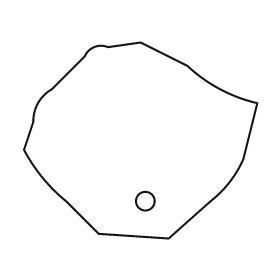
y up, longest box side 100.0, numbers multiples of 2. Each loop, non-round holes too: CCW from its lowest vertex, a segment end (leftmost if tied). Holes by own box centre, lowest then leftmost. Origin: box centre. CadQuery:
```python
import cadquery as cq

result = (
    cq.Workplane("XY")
    .moveTo(12.0, -42.0)
    .lineTo(30.0, -26.0)
    .threePointArc((38.0, -18.0), (44.0, -8.0))
    .lineTo(50.0, 16.0)
    .threePointArc((34.0, 22.0), (20.0, 32.0))
    .lineTo(0.0, 42.0)
    .lineTo(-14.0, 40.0)
    .threePointArc((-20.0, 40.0), (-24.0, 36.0))
    .lineTo(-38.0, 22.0)
    .threePointArc((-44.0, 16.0), (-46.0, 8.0))
    .lineTo(-50.0, -4.0)
    .threePointArc((-42.0, -16.0), (-32.0, -26.0))
    .lineTo(-18.0, -40.0)
    .close()
    .moveTo(2.0, -26.0)
    .circle(4.0)
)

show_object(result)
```